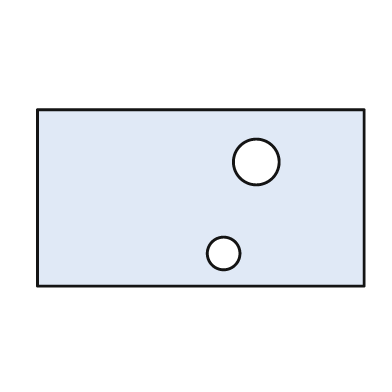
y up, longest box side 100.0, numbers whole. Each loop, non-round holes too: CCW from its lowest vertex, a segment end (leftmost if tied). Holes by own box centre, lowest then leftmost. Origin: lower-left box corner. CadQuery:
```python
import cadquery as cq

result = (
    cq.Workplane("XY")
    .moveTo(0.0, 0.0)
    .lineTo(100.0, 0.0)
    .lineTo(100.0, 54.0)
    .lineTo(0.0, 54.0)
    .close()
    .moveTo(57.0, 10.0)
    .circle(5.0)
    .moveTo(67.0, 38.0)
    .circle(7.0)
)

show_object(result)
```